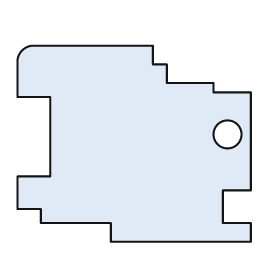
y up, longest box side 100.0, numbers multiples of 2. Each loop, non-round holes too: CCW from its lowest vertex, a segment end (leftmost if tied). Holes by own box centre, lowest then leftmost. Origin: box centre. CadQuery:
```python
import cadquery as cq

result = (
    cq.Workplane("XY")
    .moveTo(-10.0, -42.0)
    .lineTo(50.0, -42.0)
    .lineTo(50.0, -34.0)
    .lineTo(38.0, -34.0)
    .lineTo(38.0, -20.0)
    .lineTo(50.0, -20.0)
    .lineTo(50.0, 22.0)
    .lineTo(34.0, 22.0)
    .lineTo(34.0, 26.0)
    .lineTo(14.0, 26.0)
    .lineTo(14.0, 34.0)
    .lineTo(8.0, 34.0)
    .lineTo(8.0, 42.0)
    .lineTo(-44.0, 42.0)
    .threePointArc((-48.0, 40.0), (-50.0, 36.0))
    .lineTo(-50.0, 20.0)
    .lineTo(-36.0, 20.0)
    .lineTo(-36.0, -14.0)
    .lineTo(-50.0, -14.0)
    .lineTo(-50.0, -28.0)
    .lineTo(-40.0, -28.0)
    .lineTo(-40.0, -34.0)
    .lineTo(-10.0, -34.0)
    .close()
    .moveTo(40.0, 4.0)
    .circle(6.0)
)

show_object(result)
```